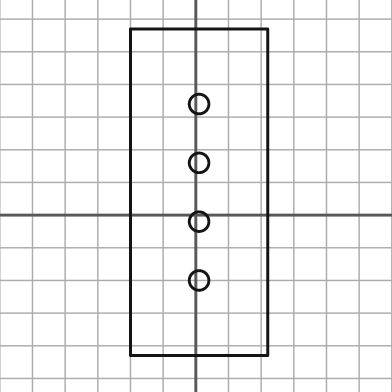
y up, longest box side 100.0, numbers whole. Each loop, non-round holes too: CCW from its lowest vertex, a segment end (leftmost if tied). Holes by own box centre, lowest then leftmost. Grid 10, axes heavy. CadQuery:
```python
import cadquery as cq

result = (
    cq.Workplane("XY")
    .moveTo(-20.0, -43.0)
    .lineTo(22.0, -43.0)
    .lineTo(22.0, 57.0)
    .lineTo(-20.0, 57.0)
    .close()
    .moveTo(1.0, -20.0)
    .circle(3.0)
    .moveTo(1.0, -2.0)
    .circle(3.0)
    .moveTo(1.0, 16.0)
    .circle(3.0)
    .moveTo(1.0, 34.0)
    .circle(3.0)
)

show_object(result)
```